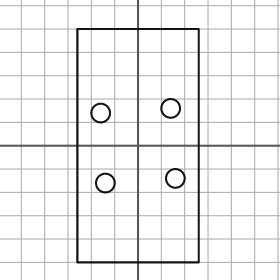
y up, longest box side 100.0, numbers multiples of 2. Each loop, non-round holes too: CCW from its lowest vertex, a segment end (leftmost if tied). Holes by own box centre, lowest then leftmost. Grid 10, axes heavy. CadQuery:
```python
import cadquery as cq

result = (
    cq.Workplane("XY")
    .moveTo(-26.0, -50.0)
    .lineTo(26.0, -50.0)
    .lineTo(26.0, 50.0)
    .lineTo(-26.0, 50.0)
    .close()
    .moveTo(-14.0, -16.0)
    .circle(4.0)
    .moveTo(16.0, -14.0)
    .circle(4.0)
    .moveTo(-16.0, 14.0)
    .circle(4.0)
    .moveTo(14.0, 16.0)
    .circle(4.0)
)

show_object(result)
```